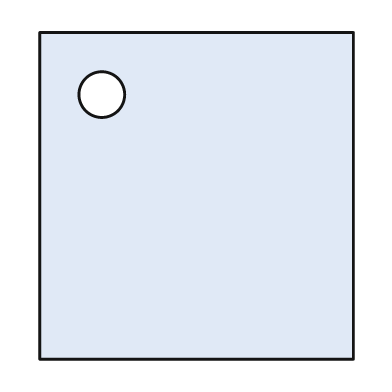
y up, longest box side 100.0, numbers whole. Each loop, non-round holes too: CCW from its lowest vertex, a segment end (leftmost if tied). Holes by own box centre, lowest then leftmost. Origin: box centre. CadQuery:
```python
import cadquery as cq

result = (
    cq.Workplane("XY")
    .moveTo(-48.0, -50.0)
    .lineTo(48.0, -50.0)
    .lineTo(48.0, 50.0)
    .lineTo(-48.0, 50.0)
    .close()
    .moveTo(-29.0, 31.0)
    .circle(7.0)
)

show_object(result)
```